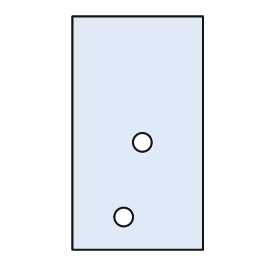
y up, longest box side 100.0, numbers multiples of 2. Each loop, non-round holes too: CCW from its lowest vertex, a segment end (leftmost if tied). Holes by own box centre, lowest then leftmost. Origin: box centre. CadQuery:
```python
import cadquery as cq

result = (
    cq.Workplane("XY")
    .moveTo(-28.0, -50.0)
    .lineTo(28.0, -50.0)
    .lineTo(28.0, 50.0)
    .lineTo(-28.0, 50.0)
    .close()
    .moveTo(-6.0, -36.0)
    .circle(4.0)
    .moveTo(2.0, -4.0)
    .circle(4.0)
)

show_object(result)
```